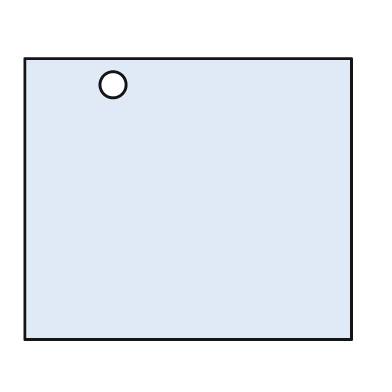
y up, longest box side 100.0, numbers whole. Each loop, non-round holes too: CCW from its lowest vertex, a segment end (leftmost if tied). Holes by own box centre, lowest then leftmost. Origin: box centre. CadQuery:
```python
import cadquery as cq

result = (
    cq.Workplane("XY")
    .moveTo(-50.0, -43.0)
    .lineTo(50.0, -43.0)
    .lineTo(50.0, 43.0)
    .lineTo(-50.0, 43.0)
    .close()
    .moveTo(-23.0, 35.0)
    .circle(4.0)
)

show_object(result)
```